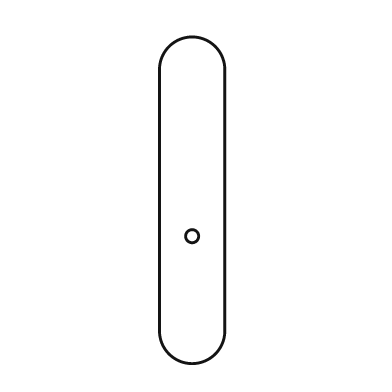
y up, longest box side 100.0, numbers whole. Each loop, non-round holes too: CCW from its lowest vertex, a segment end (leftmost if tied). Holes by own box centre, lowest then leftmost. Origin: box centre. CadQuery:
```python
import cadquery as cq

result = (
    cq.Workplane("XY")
    .moveTo(-10.0, -40.0)
    .threePointArc((0.0, -50.0), (10.0, -40.0))
    .lineTo(10.0, 40.0)
    .threePointArc((0.0, 50.0), (-10.0, 40.0))
    .close()
    .moveTo(0.0, -11.0)
    .circle(2.0)
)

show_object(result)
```